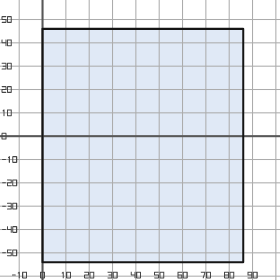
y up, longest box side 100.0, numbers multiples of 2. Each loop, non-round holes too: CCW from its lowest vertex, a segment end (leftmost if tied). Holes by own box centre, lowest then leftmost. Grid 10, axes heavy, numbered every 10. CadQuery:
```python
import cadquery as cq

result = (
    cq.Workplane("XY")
    .moveTo(0.0, -54.0)
    .lineTo(86.0, -54.0)
    .lineTo(86.0, 46.0)
    .lineTo(0.0, 46.0)
    .close()
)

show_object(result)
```